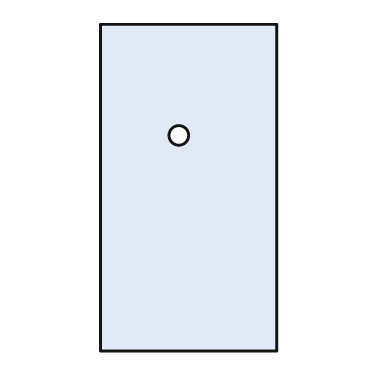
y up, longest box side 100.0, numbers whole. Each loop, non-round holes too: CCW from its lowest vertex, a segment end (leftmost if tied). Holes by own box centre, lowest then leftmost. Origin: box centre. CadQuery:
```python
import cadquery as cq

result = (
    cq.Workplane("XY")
    .moveTo(-27.0, -50.0)
    .lineTo(27.0, -50.0)
    .lineTo(27.0, 50.0)
    .lineTo(-27.0, 50.0)
    .close()
    .moveTo(-3.0, 16.0)
    .circle(3.0)
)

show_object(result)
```